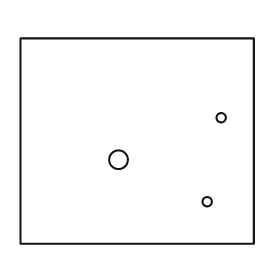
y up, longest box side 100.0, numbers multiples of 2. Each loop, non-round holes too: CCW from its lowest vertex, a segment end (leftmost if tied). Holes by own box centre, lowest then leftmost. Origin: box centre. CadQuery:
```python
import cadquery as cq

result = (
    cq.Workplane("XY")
    .moveTo(-50.0, -44.0)
    .lineTo(50.0, -44.0)
    .lineTo(50.0, 44.0)
    .lineTo(-50.0, 44.0)
    .close()
    .moveTo(30.0, -26.0)
    .circle(2.0)
    .moveTo(-8.0, -8.0)
    .circle(4.0)
    .moveTo(36.0, 10.0)
    .circle(2.0)
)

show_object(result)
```